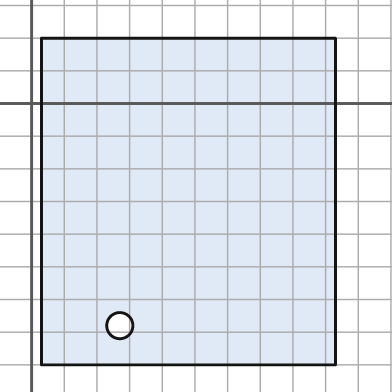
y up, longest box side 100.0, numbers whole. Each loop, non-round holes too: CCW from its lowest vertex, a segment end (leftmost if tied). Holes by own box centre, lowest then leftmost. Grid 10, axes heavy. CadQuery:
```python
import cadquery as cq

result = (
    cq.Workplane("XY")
    .moveTo(3.0, -80.0)
    .lineTo(93.0, -80.0)
    .lineTo(93.0, 20.0)
    .lineTo(3.0, 20.0)
    .close()
    .moveTo(27.0, -68.0)
    .circle(4.0)
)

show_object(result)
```